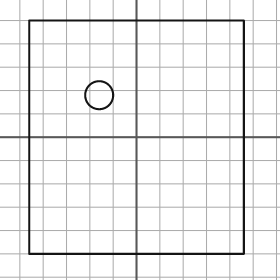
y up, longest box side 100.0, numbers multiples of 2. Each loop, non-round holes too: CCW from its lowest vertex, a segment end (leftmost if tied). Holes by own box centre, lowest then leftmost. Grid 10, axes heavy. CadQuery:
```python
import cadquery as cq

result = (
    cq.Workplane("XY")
    .moveTo(-46.0, -50.0)
    .lineTo(46.0, -50.0)
    .lineTo(46.0, 50.0)
    .lineTo(-46.0, 50.0)
    .close()
    .moveTo(-16.0, 18.0)
    .circle(6.0)
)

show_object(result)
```